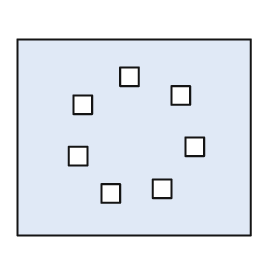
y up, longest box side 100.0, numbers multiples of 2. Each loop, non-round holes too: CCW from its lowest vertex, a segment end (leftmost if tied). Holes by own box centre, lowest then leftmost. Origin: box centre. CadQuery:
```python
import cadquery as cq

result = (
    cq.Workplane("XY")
    .moveTo(-50.0, -42.0)
    .lineTo(50.0, -42.0)
    .lineTo(50.0, 42.0)
    .lineTo(-50.0, 42.0)
    .close()
    .moveTo(-14.0, -28.0)
    .lineTo(-6.0, -28.0)
    .lineTo(-6.0, -20.0)
    .lineTo(-14.0, -20.0)
    .close()
    .moveTo(8.0, -26.0)
    .lineTo(16.0, -26.0)
    .lineTo(16.0, -18.0)
    .lineTo(8.0, -18.0)
    .close()
    .moveTo(-28.0, -12.0)
    .lineTo(-20.0, -12.0)
    .lineTo(-20.0, -4.0)
    .lineTo(-28.0, -4.0)
    .close()
    .moveTo(22.0, -8.0)
    .lineTo(30.0, -8.0)
    .lineTo(30.0, 0.0)
    .lineTo(22.0, 0.0)
    .close()
    .moveTo(-26.0, 10.0)
    .lineTo(-18.0, 10.0)
    .lineTo(-18.0, 18.0)
    .lineTo(-26.0, 18.0)
    .close()
    .moveTo(16.0, 14.0)
    .lineTo(24.0, 14.0)
    .lineTo(24.0, 22.0)
    .lineTo(16.0, 22.0)
    .close()
    .moveTo(-6.0, 22.0)
    .lineTo(2.0, 22.0)
    .lineTo(2.0, 30.0)
    .lineTo(-6.0, 30.0)
    .close()
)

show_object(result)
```